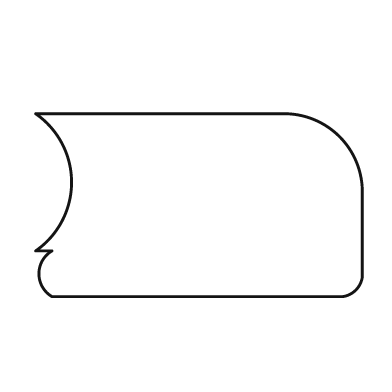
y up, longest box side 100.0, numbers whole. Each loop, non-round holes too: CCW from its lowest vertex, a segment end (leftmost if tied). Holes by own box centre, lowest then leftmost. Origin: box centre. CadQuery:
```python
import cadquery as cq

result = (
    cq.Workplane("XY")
    .moveTo(-45.0, -28.0)
    .lineTo(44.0, -28.0)
    .threePointArc((48.0, -26.0), (50.0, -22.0))
    .lineTo(50.0, 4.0)
    .threePointArc((43.0, 21.0), (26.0, 28.0))
    .lineTo(-50.0, 28.0)
    .threePointArc((-39.0, 7.0), (-50.0, -14.0))
    .lineTo(-45.0, -14.0)
    .threePointArc((-49.0, -21.0), (-45.0, -28.0))
    .close()
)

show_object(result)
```